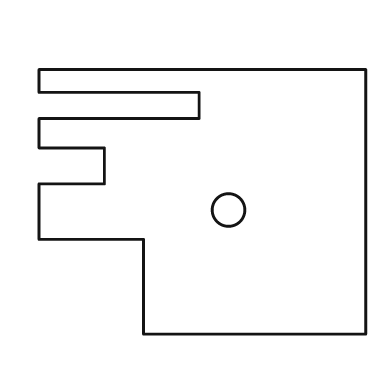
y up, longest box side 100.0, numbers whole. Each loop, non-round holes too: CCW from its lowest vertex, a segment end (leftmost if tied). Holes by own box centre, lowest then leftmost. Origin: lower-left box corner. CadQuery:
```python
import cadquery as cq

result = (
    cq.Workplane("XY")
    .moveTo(32.0, 0.0)
    .lineTo(100.0, 0.0)
    .lineTo(100.0, 81.0)
    .lineTo(0.0, 81.0)
    .lineTo(0.0, 74.0)
    .lineTo(49.0, 74.0)
    .lineTo(49.0, 66.0)
    .lineTo(0.0, 66.0)
    .lineTo(0.0, 57.0)
    .lineTo(20.0, 57.0)
    .lineTo(20.0, 46.0)
    .lineTo(0.0, 46.0)
    .lineTo(0.0, 29.0)
    .lineTo(32.0, 29.0)
    .close()
    .moveTo(58.0, 38.0)
    .circle(5.0)
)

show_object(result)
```